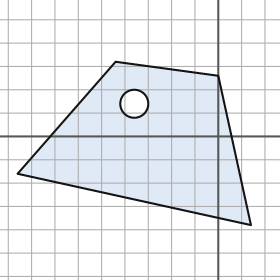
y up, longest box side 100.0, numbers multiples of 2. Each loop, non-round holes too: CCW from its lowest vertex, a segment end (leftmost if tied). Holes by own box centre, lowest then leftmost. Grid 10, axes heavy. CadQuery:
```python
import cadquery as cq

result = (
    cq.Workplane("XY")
    .moveTo(14.0, -38.0)
    .lineTo(0.0, 26.0)
    .lineTo(-44.0, 32.0)
    .lineTo(-86.0, -16.0)
    .close()
    .moveTo(-36.0, 14.0)
    .circle(6.0)
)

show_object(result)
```